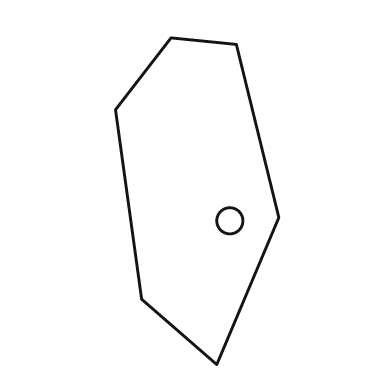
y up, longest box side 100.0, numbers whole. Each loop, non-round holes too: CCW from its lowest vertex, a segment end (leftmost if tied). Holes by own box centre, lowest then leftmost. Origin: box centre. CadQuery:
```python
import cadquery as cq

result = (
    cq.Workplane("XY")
    .moveTo(6.0, -50.0)
    .lineTo(25.0, -5.0)
    .lineTo(12.0, 48.0)
    .lineTo(-8.0, 50.0)
    .lineTo(-25.0, 28.0)
    .lineTo(-17.0, -30.0)
    .close()
    .moveTo(10.0, -6.0)
    .circle(4.0)
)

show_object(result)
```